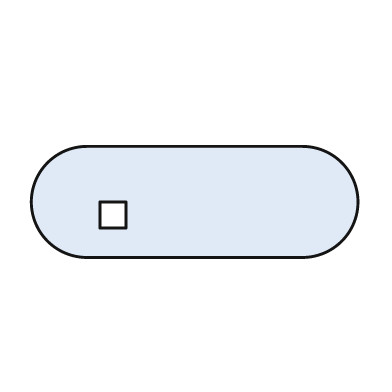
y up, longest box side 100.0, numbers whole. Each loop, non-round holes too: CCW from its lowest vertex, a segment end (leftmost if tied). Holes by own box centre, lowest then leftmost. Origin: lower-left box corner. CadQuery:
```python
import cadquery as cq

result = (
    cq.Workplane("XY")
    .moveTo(17.0, 0.0)
    .lineTo(83.0, 0.0)
    .threePointArc((100.0, 17.0), (83.0, 34.0))
    .lineTo(17.0, 34.0)
    .threePointArc((0.0, 17.0), (17.0, 0.0))
    .close()
    .moveTo(21.0, 9.0)
    .lineTo(29.0, 9.0)
    .lineTo(29.0, 17.0)
    .lineTo(21.0, 17.0)
    .close()
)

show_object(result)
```